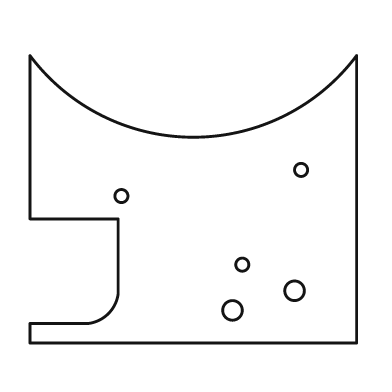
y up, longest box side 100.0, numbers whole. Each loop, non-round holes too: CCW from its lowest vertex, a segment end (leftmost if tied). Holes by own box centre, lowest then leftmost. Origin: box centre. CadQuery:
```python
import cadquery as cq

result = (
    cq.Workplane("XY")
    .moveTo(-50.0, -44.0)
    .lineTo(50.0, -44.0)
    .lineTo(50.0, 44.0)
    .threePointArc((0.0, 19.0), (-50.0, 44.0))
    .lineTo(-50.0, -6.0)
    .lineTo(-23.0, -6.0)
    .lineTo(-23.0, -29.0)
    .threePointArc((-26.0, -35.0), (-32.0, -38.0))
    .lineTo(-50.0, -38.0)
    .close()
    .moveTo(12.0, -34.0)
    .circle(3.0)
    .moveTo(31.0, -28.0)
    .circle(3.0)
    .moveTo(15.0, -20.0)
    .circle(2.0)
    .moveTo(-22.0, 1.0)
    .circle(2.0)
    .moveTo(33.0, 9.0)
    .circle(2.0)
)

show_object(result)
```